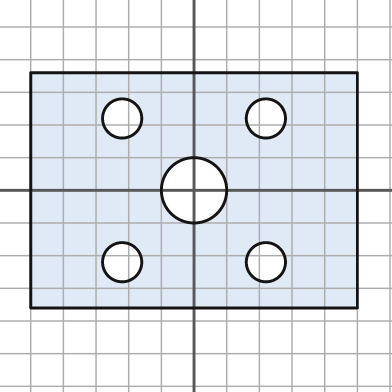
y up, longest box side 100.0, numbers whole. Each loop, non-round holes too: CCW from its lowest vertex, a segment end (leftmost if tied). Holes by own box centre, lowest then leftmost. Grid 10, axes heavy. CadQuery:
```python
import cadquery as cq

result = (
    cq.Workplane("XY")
    .moveTo(-50.0, -36.0)
    .lineTo(50.0, -36.0)
    .lineTo(50.0, 36.0)
    .lineTo(-50.0, 36.0)
    .close()
    .moveTo(-22.0, -22.0)
    .circle(6.0)
    .moveTo(22.0, -22.0)
    .circle(6.0)
    .moveTo(0.0, 0.0)
    .circle(10.0)
    .moveTo(-22.0, 22.0)
    .circle(6.0)
    .moveTo(22.0, 22.0)
    .circle(6.0)
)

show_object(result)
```